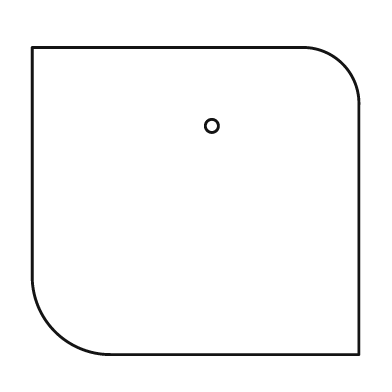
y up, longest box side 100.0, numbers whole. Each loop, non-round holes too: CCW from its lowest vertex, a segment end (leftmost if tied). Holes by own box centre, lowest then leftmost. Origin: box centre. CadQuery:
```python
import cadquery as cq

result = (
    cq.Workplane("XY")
    .moveTo(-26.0, -47.0)
    .lineTo(50.0, -47.0)
    .lineTo(50.0, 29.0)
    .threePointArc((45.0, 42.0), (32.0, 47.0))
    .lineTo(-50.0, 47.0)
    .lineTo(-50.0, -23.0)
    .threePointArc((-43.0, -40.0), (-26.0, -47.0))
    .close()
    .moveTo(5.0, 23.0)
    .circle(2.0)
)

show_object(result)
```